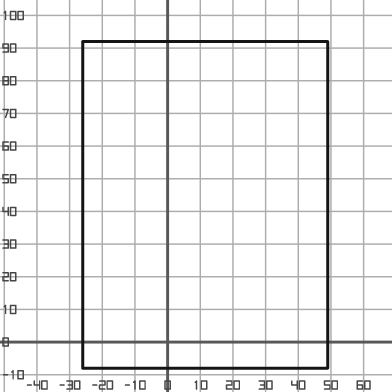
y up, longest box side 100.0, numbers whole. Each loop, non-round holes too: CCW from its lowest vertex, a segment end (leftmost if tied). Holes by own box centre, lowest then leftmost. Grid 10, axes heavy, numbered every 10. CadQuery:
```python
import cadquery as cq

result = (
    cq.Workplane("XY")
    .moveTo(-26.0, -8.0)
    .lineTo(49.0, -8.0)
    .lineTo(49.0, 92.0)
    .lineTo(-26.0, 92.0)
    .close()
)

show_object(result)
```